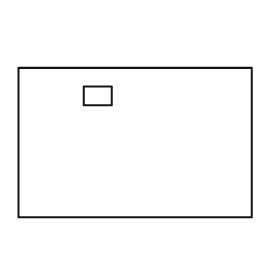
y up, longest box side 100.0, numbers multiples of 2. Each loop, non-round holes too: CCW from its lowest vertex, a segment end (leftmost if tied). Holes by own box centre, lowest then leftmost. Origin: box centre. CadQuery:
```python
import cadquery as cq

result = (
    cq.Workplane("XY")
    .moveTo(-50.0, -32.0)
    .lineTo(50.0, -32.0)
    .lineTo(50.0, 32.0)
    .lineTo(-50.0, 32.0)
    .close()
    .moveTo(-22.0, 16.0)
    .lineTo(-10.0, 16.0)
    .lineTo(-10.0, 24.0)
    .lineTo(-22.0, 24.0)
    .close()
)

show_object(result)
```